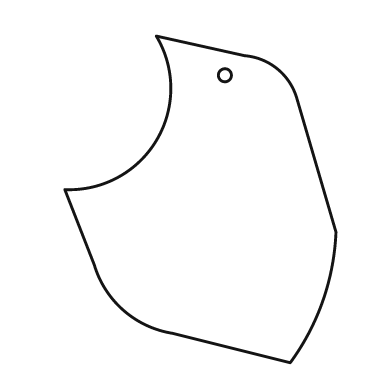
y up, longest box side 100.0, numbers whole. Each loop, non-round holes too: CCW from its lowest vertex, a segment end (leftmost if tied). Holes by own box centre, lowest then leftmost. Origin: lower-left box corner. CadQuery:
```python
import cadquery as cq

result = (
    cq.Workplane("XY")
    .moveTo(69.0, 0.0)
    .threePointArc((79.0, 19.0), (83.0, 40.0))
    .lineTo(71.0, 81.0)
    .threePointArc((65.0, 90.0), (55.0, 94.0))
    .lineTo(28.0, 100.0)
    .threePointArc((28.0, 68.0), (0.0, 53.0))
    .lineTo(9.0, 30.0)
    .threePointArc((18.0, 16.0), (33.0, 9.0))
    .close()
    .moveTo(49.0, 88.0)
    .circle(2.0)
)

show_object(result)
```